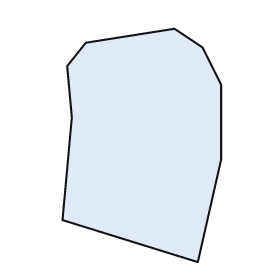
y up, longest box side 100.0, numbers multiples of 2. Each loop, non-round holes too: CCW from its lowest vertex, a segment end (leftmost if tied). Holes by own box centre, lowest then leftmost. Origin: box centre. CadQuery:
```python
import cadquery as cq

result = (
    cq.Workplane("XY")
    .moveTo(24.0, -50.0)
    .lineTo(34.0, -6.0)
    .lineTo(34.0, 26.0)
    .lineTo(26.0, 42.0)
    .lineTo(14.0, 50.0)
    .lineTo(-24.0, 44.0)
    .lineTo(-32.0, 34.0)
    .lineTo(-30.0, 12.0)
    .lineTo(-34.0, -32.0)
    .close()
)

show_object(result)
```